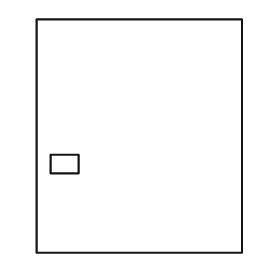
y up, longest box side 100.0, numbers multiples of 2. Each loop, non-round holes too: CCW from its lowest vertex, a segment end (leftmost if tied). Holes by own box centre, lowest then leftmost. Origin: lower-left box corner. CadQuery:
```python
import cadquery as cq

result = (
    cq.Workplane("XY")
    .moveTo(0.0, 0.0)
    .lineTo(88.0, 0.0)
    .lineTo(88.0, 100.0)
    .lineTo(0.0, 100.0)
    .close()
    .moveTo(6.0, 34.0)
    .lineTo(18.0, 34.0)
    .lineTo(18.0, 42.0)
    .lineTo(6.0, 42.0)
    .close()
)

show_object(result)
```